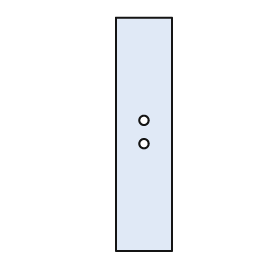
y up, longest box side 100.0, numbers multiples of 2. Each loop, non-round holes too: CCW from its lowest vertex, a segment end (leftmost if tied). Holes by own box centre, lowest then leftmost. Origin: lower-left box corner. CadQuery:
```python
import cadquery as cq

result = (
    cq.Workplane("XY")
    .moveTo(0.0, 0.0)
    .lineTo(24.0, 0.0)
    .lineTo(24.0, 100.0)
    .lineTo(0.0, 100.0)
    .close()
    .moveTo(12.0, 46.0)
    .circle(2.0)
    .moveTo(12.0, 56.0)
    .circle(2.0)
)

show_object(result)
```